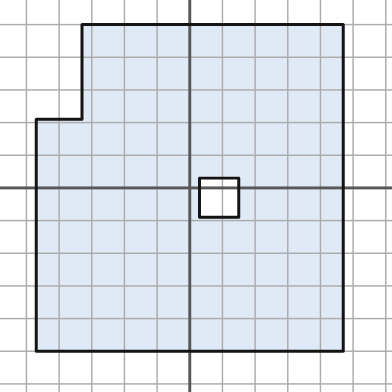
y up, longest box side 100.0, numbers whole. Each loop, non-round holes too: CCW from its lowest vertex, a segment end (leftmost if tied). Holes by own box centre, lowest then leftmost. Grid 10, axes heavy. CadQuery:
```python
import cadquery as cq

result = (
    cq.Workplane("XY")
    .moveTo(-47.0, -50.0)
    .lineTo(47.0, -50.0)
    .lineTo(47.0, 50.0)
    .lineTo(-33.0, 50.0)
    .lineTo(-33.0, 21.0)
    .lineTo(-47.0, 21.0)
    .close()
    .moveTo(3.0, -9.0)
    .lineTo(15.0, -9.0)
    .lineTo(15.0, 3.0)
    .lineTo(3.0, 3.0)
    .close()
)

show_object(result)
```